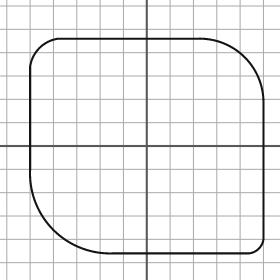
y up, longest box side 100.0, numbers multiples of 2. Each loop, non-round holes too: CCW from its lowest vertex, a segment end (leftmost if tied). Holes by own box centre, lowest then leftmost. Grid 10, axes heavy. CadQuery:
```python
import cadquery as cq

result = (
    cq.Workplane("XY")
    .moveTo(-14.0, -46.0)
    .lineTo(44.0, -46.0)
    .threePointArc((48.0, -44.0), (50.0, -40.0))
    .lineTo(50.0, 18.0)
    .threePointArc((42.0, 38.0), (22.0, 46.0))
    .lineTo(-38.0, 46.0)
    .threePointArc((-46.0, 42.0), (-50.0, 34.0))
    .lineTo(-50.0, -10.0)
    .threePointArc((-40.0, -36.0), (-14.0, -46.0))
    .close()
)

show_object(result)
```